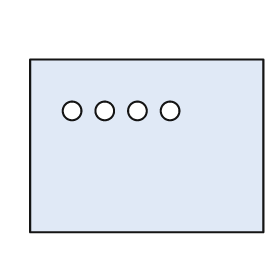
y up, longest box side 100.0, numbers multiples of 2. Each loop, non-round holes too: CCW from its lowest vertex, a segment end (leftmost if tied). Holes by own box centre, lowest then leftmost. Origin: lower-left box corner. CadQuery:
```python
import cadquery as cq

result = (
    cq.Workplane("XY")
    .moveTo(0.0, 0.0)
    .lineTo(100.0, 0.0)
    .lineTo(100.0, 74.0)
    .lineTo(0.0, 74.0)
    .close()
    .moveTo(18.0, 52.0)
    .circle(4.0)
    .moveTo(32.0, 52.0)
    .circle(4.0)
    .moveTo(46.0, 52.0)
    .circle(4.0)
    .moveTo(60.0, 52.0)
    .circle(4.0)
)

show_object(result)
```